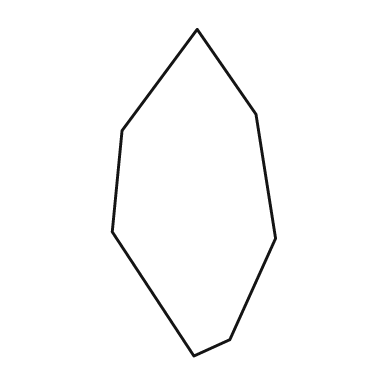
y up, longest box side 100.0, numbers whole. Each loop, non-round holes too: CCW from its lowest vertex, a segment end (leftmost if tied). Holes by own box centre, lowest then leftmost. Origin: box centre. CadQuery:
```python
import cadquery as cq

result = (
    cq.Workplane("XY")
    .moveTo(0.0, -50.0)
    .lineTo(11.0, -45.0)
    .lineTo(25.0, -14.0)
    .lineTo(19.0, 24.0)
    .lineTo(1.0, 50.0)
    .lineTo(-22.0, 19.0)
    .lineTo(-25.0, -12.0)
    .close()
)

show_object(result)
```